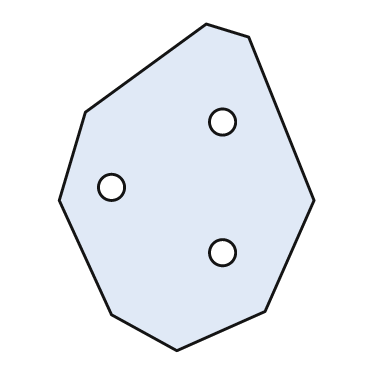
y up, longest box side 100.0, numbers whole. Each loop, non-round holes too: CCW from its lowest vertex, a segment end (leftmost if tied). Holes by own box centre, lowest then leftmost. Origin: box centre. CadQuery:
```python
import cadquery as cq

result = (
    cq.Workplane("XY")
    .moveTo(-3.0, -50.0)
    .lineTo(24.0, -38.0)
    .lineTo(39.0, -4.0)
    .lineTo(19.0, 46.0)
    .lineTo(6.0, 50.0)
    .lineTo(-31.0, 23.0)
    .lineTo(-39.0, -4.0)
    .lineTo(-23.0, -39.0)
    .close()
    .moveTo(11.0, -20.0)
    .circle(4.0)
    .moveTo(-23.0, 0.0)
    .circle(4.0)
    .moveTo(11.0, 20.0)
    .circle(4.0)
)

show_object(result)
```